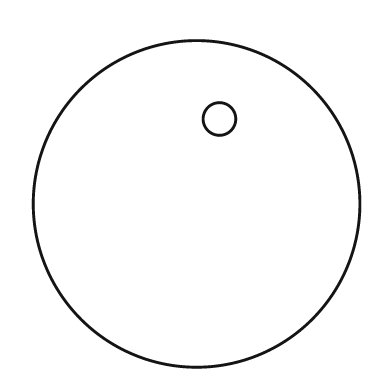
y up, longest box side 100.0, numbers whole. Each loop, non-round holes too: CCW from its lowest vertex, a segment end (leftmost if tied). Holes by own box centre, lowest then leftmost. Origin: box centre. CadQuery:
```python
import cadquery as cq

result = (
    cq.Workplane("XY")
    .moveTo(0.0, 0.0)
    .circle(50.0)
    .moveTo(7.0, 26.0)
    .circle(5.0)
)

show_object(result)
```